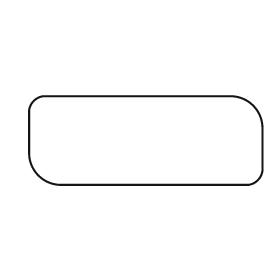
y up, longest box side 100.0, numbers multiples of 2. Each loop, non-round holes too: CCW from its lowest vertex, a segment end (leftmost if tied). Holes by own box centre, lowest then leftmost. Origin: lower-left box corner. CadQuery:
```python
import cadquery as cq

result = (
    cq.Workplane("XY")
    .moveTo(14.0, 0.0)
    .lineTo(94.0, 0.0)
    .threePointArc((98.0, 2.0), (100.0, 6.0))
    .lineTo(100.0, 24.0)
    .threePointArc((96.0, 34.0), (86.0, 38.0))
    .lineTo(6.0, 38.0)
    .threePointArc((2.0, 36.0), (0.0, 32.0))
    .lineTo(0.0, 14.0)
    .threePointArc((4.0, 4.0), (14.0, 0.0))
    .close()
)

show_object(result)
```